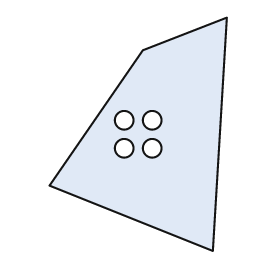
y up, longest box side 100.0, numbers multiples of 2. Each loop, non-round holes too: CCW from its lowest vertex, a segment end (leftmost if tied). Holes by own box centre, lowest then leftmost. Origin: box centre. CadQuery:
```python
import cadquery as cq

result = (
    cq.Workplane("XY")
    .moveTo(32.0, -50.0)
    .lineTo(38.0, 50.0)
    .lineTo(2.0, 36.0)
    .lineTo(-38.0, -22.0)
    .close()
    .moveTo(-6.0, -6.0)
    .circle(4.0)
    .moveTo(6.0, -6.0)
    .circle(4.0)
    .moveTo(-6.0, 6.0)
    .circle(4.0)
    .moveTo(6.0, 6.0)
    .circle(4.0)
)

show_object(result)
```